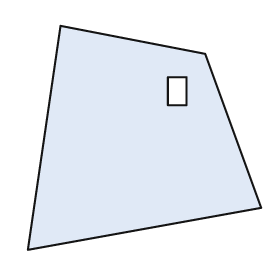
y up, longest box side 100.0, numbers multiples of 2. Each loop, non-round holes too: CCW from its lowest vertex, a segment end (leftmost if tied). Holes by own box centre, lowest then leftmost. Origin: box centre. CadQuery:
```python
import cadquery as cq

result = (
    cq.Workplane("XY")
    .moveTo(-50.0, -48.0)
    .lineTo(50.0, -30.0)
    .lineTo(26.0, 36.0)
    .lineTo(-36.0, 48.0)
    .close()
    .moveTo(10.0, 14.0)
    .lineTo(18.0, 14.0)
    .lineTo(18.0, 26.0)
    .lineTo(10.0, 26.0)
    .close()
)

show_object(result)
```